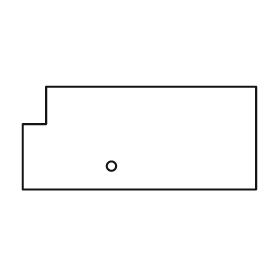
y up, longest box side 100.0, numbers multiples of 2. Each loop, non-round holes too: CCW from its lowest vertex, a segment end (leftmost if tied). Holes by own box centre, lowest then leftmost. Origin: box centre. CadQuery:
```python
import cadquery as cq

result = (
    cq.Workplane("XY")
    .moveTo(-50.0, -22.0)
    .lineTo(50.0, -22.0)
    .lineTo(50.0, 22.0)
    .lineTo(-40.0, 22.0)
    .lineTo(-40.0, 6.0)
    .lineTo(-50.0, 6.0)
    .close()
    .moveTo(-12.0, -12.0)
    .circle(2.0)
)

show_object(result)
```